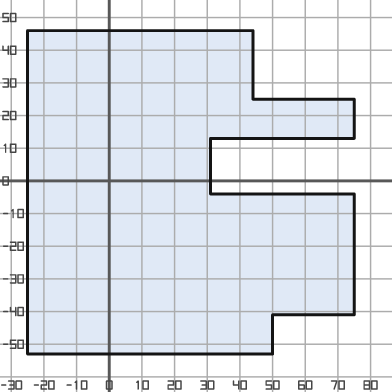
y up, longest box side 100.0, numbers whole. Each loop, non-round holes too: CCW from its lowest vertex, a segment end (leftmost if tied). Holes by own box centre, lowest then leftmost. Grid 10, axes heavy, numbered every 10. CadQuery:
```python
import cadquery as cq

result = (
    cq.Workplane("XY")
    .moveTo(-25.0, -53.0)
    .lineTo(50.0, -53.0)
    .lineTo(50.0, -41.0)
    .lineTo(75.0, -41.0)
    .lineTo(75.0, -4.0)
    .lineTo(31.0, -4.0)
    .lineTo(31.0, 13.0)
    .lineTo(75.0, 13.0)
    .lineTo(75.0, 25.0)
    .lineTo(44.0, 25.0)
    .lineTo(44.0, 46.0)
    .lineTo(-25.0, 46.0)
    .close()
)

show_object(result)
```